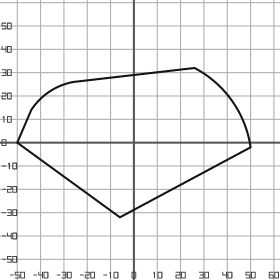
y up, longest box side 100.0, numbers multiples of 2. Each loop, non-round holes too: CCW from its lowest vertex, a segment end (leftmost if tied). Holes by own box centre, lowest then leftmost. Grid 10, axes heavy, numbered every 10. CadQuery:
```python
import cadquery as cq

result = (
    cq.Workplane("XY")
    .moveTo(-6.0, -32.0)
    .lineTo(50.0, -2.0)
    .threePointArc((42.0, 18.0), (26.0, 32.0))
    .lineTo(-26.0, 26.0)
    .threePointArc((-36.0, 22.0), (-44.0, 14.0))
    .lineTo(-50.0, 0.0)
    .close()
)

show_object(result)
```